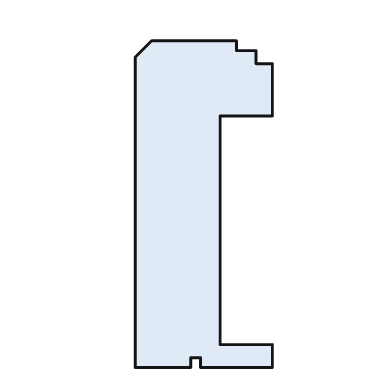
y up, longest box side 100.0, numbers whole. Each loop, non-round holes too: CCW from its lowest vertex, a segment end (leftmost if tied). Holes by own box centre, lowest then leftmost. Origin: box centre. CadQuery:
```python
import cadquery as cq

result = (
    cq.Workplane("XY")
    .moveTo(-21.0, -50.0)
    .lineTo(-4.0, -50.0)
    .lineTo(-4.0, -47.0)
    .lineTo(-1.0, -47.0)
    .lineTo(-1.0, -50.0)
    .lineTo(21.0, -50.0)
    .lineTo(21.0, -43.0)
    .lineTo(5.0, -43.0)
    .lineTo(5.0, 27.0)
    .lineTo(21.0, 27.0)
    .lineTo(21.0, 43.0)
    .lineTo(16.0, 43.0)
    .lineTo(16.0, 47.0)
    .lineTo(10.0, 47.0)
    .lineTo(10.0, 50.0)
    .lineTo(-16.0, 50.0)
    .lineTo(-21.0, 45.0)
    .close()
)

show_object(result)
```